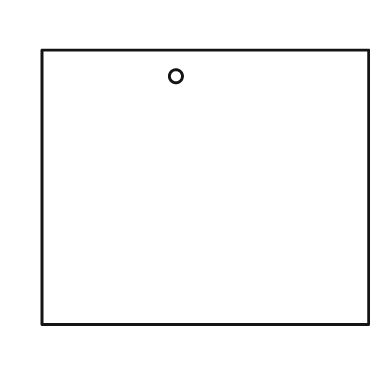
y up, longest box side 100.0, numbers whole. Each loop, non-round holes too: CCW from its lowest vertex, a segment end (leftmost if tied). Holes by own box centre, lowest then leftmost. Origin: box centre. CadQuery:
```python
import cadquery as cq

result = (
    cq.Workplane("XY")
    .moveTo(-50.0, -42.0)
    .lineTo(50.0, -42.0)
    .lineTo(50.0, 42.0)
    .lineTo(-50.0, 42.0)
    .close()
    .moveTo(-9.0, 34.0)
    .circle(2.0)
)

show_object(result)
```